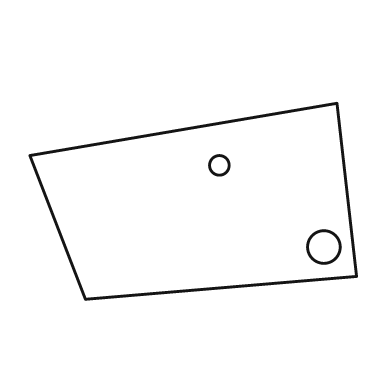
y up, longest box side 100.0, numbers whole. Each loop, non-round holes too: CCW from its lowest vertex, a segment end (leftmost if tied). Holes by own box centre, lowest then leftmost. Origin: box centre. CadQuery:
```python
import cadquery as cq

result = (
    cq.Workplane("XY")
    .moveTo(-33.0, -30.0)
    .lineTo(50.0, -23.0)
    .lineTo(44.0, 30.0)
    .lineTo(-50.0, 14.0)
    .close()
    .moveTo(40.0, -14.0)
    .circle(5.0)
    .moveTo(8.0, 11.0)
    .circle(3.0)
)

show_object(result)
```